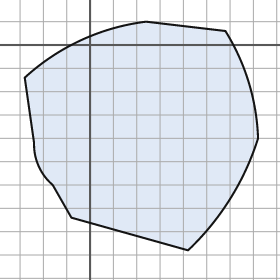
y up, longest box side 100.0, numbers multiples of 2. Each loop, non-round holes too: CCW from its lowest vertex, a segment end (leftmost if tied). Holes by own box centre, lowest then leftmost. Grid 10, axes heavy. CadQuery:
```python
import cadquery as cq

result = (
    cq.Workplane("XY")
    .moveTo(42.0, -88.0)
    .threePointArc((60.0, -66.0), (72.0, -40.0))
    .threePointArc((68.0, -16.0), (58.0, 6.0))
    .lineTo(24.0, 10.0)
    .threePointArc((-4.0, 2.0), (-28.0, -14.0))
    .lineTo(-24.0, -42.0)
    .threePointArc((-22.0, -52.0), (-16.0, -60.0))
    .lineTo(-8.0, -74.0)
    .close()
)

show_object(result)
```